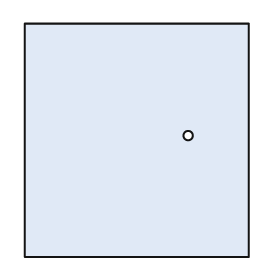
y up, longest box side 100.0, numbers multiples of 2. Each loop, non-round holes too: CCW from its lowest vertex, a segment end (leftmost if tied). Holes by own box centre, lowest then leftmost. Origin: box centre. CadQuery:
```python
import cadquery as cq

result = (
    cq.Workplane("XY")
    .moveTo(-48.0, -50.0)
    .lineTo(48.0, -50.0)
    .lineTo(48.0, 50.0)
    .lineTo(-48.0, 50.0)
    .close()
    .moveTo(22.0, 2.0)
    .circle(2.0)
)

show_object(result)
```